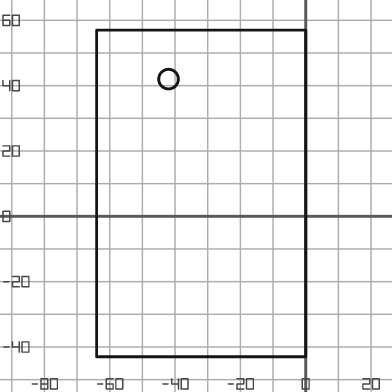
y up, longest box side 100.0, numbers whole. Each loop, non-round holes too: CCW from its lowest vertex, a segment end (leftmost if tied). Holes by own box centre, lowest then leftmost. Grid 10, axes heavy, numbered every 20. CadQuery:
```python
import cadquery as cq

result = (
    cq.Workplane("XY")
    .moveTo(-64.0, -43.0)
    .lineTo(0.0, -43.0)
    .lineTo(0.0, 57.0)
    .lineTo(-64.0, 57.0)
    .close()
    .moveTo(-42.0, 42.0)
    .circle(3.0)
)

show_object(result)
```